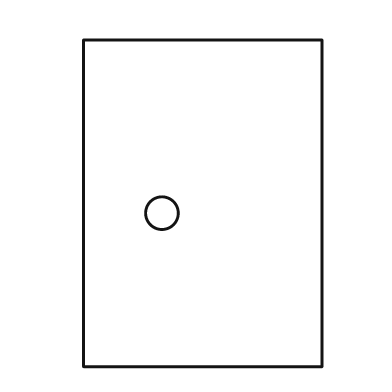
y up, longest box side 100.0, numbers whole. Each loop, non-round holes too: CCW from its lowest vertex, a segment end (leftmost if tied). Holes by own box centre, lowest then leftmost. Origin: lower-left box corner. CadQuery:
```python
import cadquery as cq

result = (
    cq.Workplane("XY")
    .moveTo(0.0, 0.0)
    .lineTo(73.0, 0.0)
    .lineTo(73.0, 100.0)
    .lineTo(0.0, 100.0)
    .close()
    .moveTo(24.0, 47.0)
    .circle(5.0)
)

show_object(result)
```